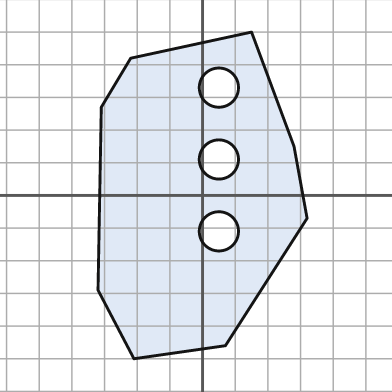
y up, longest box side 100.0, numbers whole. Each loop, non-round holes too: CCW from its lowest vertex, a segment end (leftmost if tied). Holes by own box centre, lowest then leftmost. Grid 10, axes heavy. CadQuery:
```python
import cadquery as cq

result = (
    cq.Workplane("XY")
    .moveTo(-21.0, -50.0)
    .lineTo(7.0, -46.0)
    .lineTo(32.0, -7.0)
    .lineTo(28.0, 15.0)
    .lineTo(15.0, 50.0)
    .lineTo(-22.0, 42.0)
    .lineTo(-31.0, 27.0)
    .lineTo(-32.0, -29.0)
    .close()
    .moveTo(5.0, -11.0)
    .circle(6.0)
    .moveTo(5.0, 11.0)
    .circle(6.0)
    .moveTo(5.0, 33.0)
    .circle(6.0)
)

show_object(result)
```